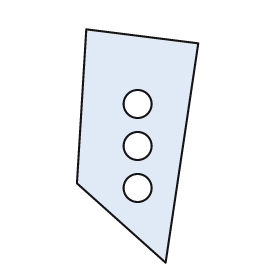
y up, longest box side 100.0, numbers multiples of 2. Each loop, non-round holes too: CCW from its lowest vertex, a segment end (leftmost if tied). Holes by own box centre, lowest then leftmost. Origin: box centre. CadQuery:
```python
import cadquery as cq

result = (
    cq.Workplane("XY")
    .moveTo(12.0, -50.0)
    .lineTo(26.0, 44.0)
    .lineTo(-22.0, 50.0)
    .lineTo(-26.0, -16.0)
    .close()
    .moveTo(0.0, -18.0)
    .circle(6.0)
    .moveTo(0.0, 0.0)
    .circle(6.0)
    .moveTo(0.0, 18.0)
    .circle(6.0)
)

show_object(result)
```